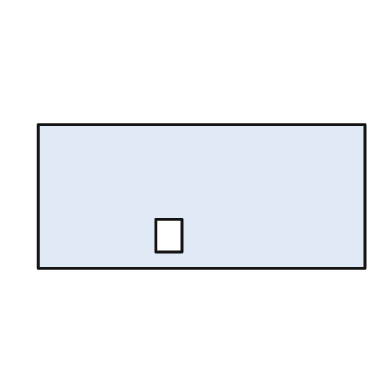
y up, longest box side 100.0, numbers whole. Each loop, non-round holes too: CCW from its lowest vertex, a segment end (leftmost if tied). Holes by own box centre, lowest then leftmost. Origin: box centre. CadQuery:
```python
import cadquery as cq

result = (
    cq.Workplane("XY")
    .moveTo(-50.0, -22.0)
    .lineTo(50.0, -22.0)
    .lineTo(50.0, 22.0)
    .lineTo(-50.0, 22.0)
    .close()
    .moveTo(-14.0, -17.0)
    .lineTo(-6.0, -17.0)
    .lineTo(-6.0, -7.0)
    .lineTo(-14.0, -7.0)
    .close()
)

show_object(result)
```